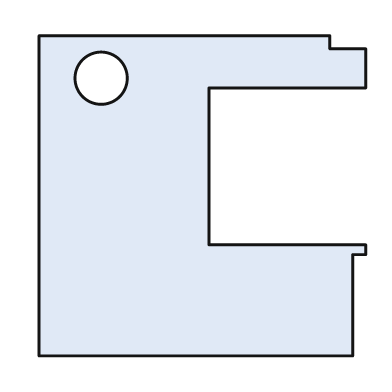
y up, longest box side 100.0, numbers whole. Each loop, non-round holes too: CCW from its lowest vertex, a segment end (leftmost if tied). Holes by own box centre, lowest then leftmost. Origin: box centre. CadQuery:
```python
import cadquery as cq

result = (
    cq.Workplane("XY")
    .moveTo(-50.0, -49.0)
    .lineTo(46.0, -49.0)
    .lineTo(46.0, -18.0)
    .lineTo(50.0, -18.0)
    .lineTo(50.0, -15.0)
    .lineTo(2.0, -15.0)
    .lineTo(2.0, 33.0)
    .lineTo(50.0, 33.0)
    .lineTo(50.0, 45.0)
    .lineTo(39.0, 45.0)
    .lineTo(39.0, 49.0)
    .lineTo(-50.0, 49.0)
    .close()
    .moveTo(-31.0, 36.0)
    .circle(8.0)
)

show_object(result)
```